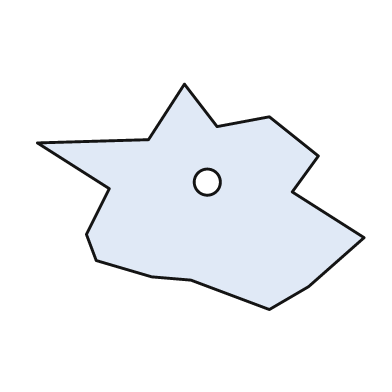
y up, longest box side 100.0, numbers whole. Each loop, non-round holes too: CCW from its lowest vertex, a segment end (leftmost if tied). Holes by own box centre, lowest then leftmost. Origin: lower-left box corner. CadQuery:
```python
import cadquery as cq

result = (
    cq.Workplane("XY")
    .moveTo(71.0, 0.0)
    .lineTo(83.0, 7.0)
    .lineTo(100.0, 22.0)
    .lineTo(78.0, 36.0)
    .lineTo(86.0, 47.0)
    .lineTo(71.0, 59.0)
    .lineTo(55.0, 56.0)
    .lineTo(45.0, 69.0)
    .lineTo(34.0, 52.0)
    .lineTo(0.0, 51.0)
    .lineTo(22.0, 37.0)
    .lineTo(15.0, 23.0)
    .lineTo(18.0, 15.0)
    .lineTo(35.0, 10.0)
    .lineTo(47.0, 9.0)
    .close()
    .moveTo(52.0, 39.0)
    .circle(4.0)
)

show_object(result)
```